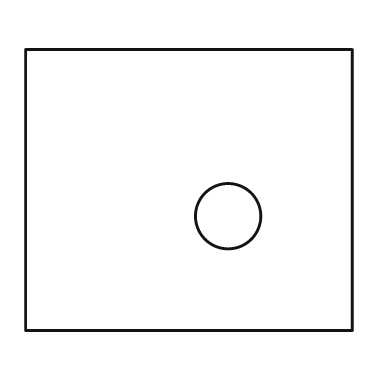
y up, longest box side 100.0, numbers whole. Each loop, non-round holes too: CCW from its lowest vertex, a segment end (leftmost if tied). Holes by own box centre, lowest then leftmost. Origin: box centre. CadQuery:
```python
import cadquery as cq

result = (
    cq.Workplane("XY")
    .moveTo(-50.0, -43.0)
    .lineTo(50.0, -43.0)
    .lineTo(50.0, 43.0)
    .lineTo(-50.0, 43.0)
    .close()
    .moveTo(12.0, -8.0)
    .circle(10.0)
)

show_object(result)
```